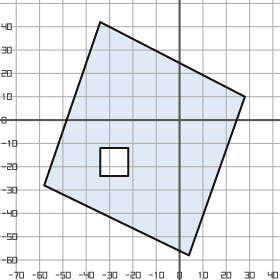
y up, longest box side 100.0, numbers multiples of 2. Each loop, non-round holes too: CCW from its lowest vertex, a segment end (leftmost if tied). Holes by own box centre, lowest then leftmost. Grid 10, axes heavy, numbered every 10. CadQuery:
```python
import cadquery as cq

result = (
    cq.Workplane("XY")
    .moveTo(4.0, -58.0)
    .lineTo(28.0, 10.0)
    .lineTo(-34.0, 42.0)
    .lineTo(-58.0, -28.0)
    .close()
    .moveTo(-34.0, -24.0)
    .lineTo(-22.0, -24.0)
    .lineTo(-22.0, -12.0)
    .lineTo(-34.0, -12.0)
    .close()
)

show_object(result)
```